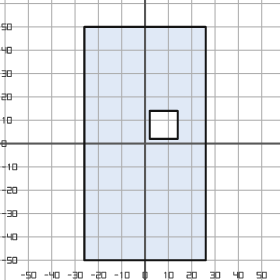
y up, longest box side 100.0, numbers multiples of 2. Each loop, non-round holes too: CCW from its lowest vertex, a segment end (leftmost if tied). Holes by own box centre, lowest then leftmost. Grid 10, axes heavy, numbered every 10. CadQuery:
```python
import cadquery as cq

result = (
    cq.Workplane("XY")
    .moveTo(-26.0, -50.0)
    .lineTo(26.0, -50.0)
    .lineTo(26.0, 50.0)
    .lineTo(-26.0, 50.0)
    .close()
    .moveTo(2.0, 2.0)
    .lineTo(14.0, 2.0)
    .lineTo(14.0, 14.0)
    .lineTo(2.0, 14.0)
    .close()
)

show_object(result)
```